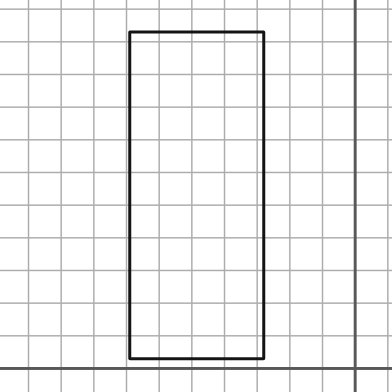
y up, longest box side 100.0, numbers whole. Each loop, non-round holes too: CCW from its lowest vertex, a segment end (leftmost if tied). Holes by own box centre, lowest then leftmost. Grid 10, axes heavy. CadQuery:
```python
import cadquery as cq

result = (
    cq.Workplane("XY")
    .moveTo(-69.0, 3.0)
    .lineTo(-28.0, 3.0)
    .lineTo(-28.0, 103.0)
    .lineTo(-69.0, 103.0)
    .close()
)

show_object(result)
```